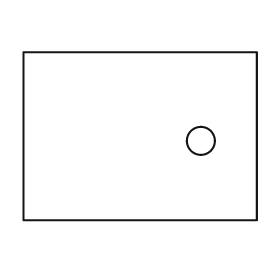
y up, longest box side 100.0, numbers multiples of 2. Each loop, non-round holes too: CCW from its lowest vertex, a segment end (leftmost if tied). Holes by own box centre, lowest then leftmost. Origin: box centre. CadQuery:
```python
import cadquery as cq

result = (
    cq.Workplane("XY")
    .moveTo(-50.0, -36.0)
    .lineTo(50.0, -36.0)
    .lineTo(50.0, 36.0)
    .lineTo(-50.0, 36.0)
    .close()
    .moveTo(26.0, -2.0)
    .circle(6.0)
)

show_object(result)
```